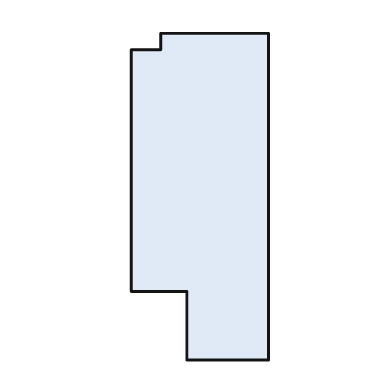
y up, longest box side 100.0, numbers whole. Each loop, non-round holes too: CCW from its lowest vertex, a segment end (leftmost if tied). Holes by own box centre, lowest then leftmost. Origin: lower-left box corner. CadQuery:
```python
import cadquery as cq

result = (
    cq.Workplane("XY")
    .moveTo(17.0, 0.0)
    .lineTo(42.0, 0.0)
    .lineTo(42.0, 100.0)
    .lineTo(9.0, 100.0)
    .lineTo(9.0, 95.0)
    .lineTo(0.0, 95.0)
    .lineTo(0.0, 21.0)
    .lineTo(17.0, 21.0)
    .close()
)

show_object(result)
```